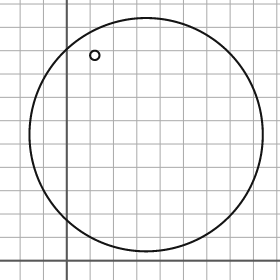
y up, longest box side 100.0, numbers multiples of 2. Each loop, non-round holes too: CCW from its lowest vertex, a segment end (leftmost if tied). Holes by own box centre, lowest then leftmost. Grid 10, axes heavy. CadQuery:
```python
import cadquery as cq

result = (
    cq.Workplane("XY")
    .moveTo(34.0, 54.0)
    .circle(50.0)
    .moveTo(12.0, 88.0)
    .circle(2.0)
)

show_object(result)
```